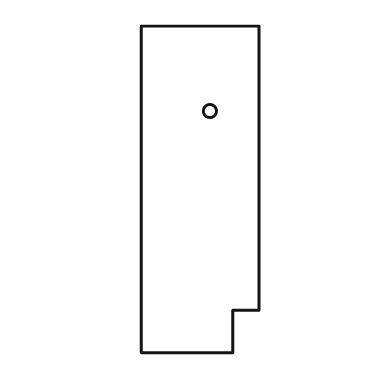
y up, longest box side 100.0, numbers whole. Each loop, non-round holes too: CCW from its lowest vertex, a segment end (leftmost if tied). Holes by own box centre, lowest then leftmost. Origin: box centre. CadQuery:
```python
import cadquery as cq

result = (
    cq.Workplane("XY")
    .moveTo(-18.0, -50.0)
    .lineTo(10.0, -50.0)
    .lineTo(10.0, -37.0)
    .lineTo(18.0, -37.0)
    .lineTo(18.0, 50.0)
    .lineTo(-18.0, 50.0)
    .close()
    .moveTo(3.0, 24.0)
    .circle(2.0)
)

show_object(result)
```